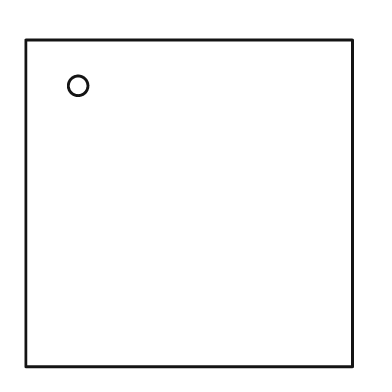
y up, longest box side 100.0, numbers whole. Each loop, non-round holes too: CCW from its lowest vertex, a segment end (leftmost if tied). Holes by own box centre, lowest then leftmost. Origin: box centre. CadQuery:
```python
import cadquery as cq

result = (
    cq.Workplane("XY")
    .moveTo(-50.0, -50.0)
    .lineTo(50.0, -50.0)
    .lineTo(50.0, 50.0)
    .lineTo(-50.0, 50.0)
    .close()
    .moveTo(-34.0, 36.0)
    .circle(3.0)
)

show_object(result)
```